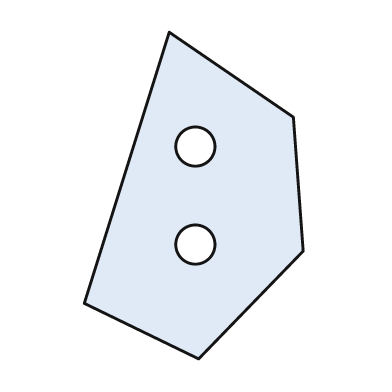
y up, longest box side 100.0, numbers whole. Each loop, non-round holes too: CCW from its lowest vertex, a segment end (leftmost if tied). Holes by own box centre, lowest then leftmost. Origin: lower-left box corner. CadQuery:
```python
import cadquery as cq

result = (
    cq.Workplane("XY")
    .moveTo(35.0, 0.0)
    .lineTo(67.0, 33.0)
    .lineTo(64.0, 74.0)
    .lineTo(26.0, 100.0)
    .lineTo(0.0, 17.0)
    .close()
    .moveTo(34.0, 35.0)
    .circle(6.0)
    .moveTo(34.0, 65.0)
    .circle(6.0)
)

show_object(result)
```